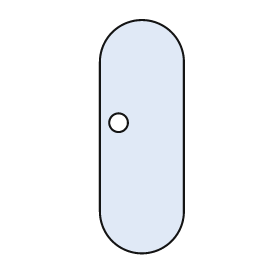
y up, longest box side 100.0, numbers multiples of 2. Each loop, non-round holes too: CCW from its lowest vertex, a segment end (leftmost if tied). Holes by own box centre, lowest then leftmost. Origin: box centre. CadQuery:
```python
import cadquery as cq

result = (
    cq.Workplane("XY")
    .moveTo(-18.0, -32.0)
    .threePointArc((0.0, -50.0), (18.0, -32.0))
    .lineTo(18.0, 32.0)
    .threePointArc((0.0, 50.0), (-18.0, 32.0))
    .close()
    .moveTo(-10.0, 6.0)
    .circle(4.0)
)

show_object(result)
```